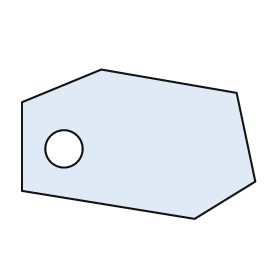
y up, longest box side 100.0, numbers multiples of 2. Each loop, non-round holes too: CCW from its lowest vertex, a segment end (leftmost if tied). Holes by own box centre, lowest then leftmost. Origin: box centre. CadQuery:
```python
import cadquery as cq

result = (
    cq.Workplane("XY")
    .moveTo(24.0, -32.0)
    .lineTo(50.0, -16.0)
    .lineTo(42.0, 22.0)
    .lineTo(-16.0, 32.0)
    .lineTo(-50.0, 18.0)
    .lineTo(-50.0, -20.0)
    .close()
    .moveTo(-32.0, -2.0)
    .circle(8.0)
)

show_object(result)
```